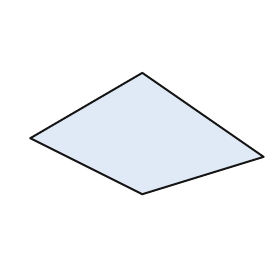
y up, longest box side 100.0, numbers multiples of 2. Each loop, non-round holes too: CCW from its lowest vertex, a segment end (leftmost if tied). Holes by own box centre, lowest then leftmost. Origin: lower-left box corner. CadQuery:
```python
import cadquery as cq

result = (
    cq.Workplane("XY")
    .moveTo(48.0, 0.0)
    .lineTo(100.0, 16.0)
    .lineTo(48.0, 52.0)
    .lineTo(0.0, 24.0)
    .close()
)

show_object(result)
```